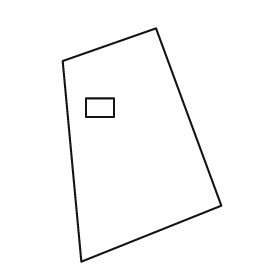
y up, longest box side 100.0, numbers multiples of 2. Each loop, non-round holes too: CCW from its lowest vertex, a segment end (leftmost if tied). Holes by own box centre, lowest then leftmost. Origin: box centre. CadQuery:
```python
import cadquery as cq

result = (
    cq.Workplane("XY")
    .moveTo(-26.0, -50.0)
    .lineTo(34.0, -26.0)
    .lineTo(6.0, 50.0)
    .lineTo(-34.0, 36.0)
    .close()
    .moveTo(-24.0, 12.0)
    .lineTo(-12.0, 12.0)
    .lineTo(-12.0, 20.0)
    .lineTo(-24.0, 20.0)
    .close()
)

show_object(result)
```